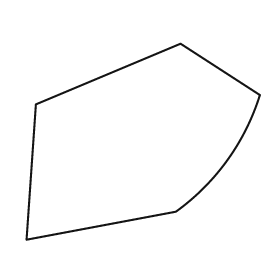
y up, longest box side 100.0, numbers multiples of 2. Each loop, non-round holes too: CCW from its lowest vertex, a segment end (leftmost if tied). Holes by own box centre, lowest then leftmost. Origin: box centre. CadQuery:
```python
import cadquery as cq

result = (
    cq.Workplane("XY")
    .moveTo(-50.0, -42.0)
    .lineTo(14.0, -30.0)
    .threePointArc((36.0, -8.0), (50.0, 20.0))
    .lineTo(16.0, 42.0)
    .lineTo(-46.0, 16.0)
    .close()
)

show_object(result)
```